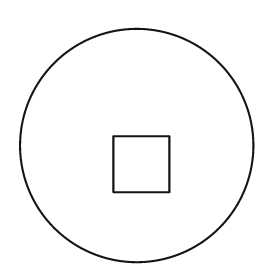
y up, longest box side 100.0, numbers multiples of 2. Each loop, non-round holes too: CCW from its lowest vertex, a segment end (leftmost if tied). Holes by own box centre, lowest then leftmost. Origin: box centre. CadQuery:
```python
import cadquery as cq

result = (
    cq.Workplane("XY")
    .moveTo(0.0, 0.0)
    .circle(50.0)
    .moveTo(-10.0, -20.0)
    .lineTo(14.0, -20.0)
    .lineTo(14.0, 4.0)
    .lineTo(-10.0, 4.0)
    .close()
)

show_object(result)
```